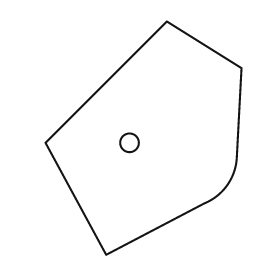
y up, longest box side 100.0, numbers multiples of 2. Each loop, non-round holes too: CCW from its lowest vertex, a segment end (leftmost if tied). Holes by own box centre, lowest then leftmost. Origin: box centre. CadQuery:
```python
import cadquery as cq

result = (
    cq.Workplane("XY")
    .moveTo(-16.0, -50.0)
    .lineTo(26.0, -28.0)
    .threePointArc((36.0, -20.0), (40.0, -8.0))
    .lineTo(42.0, 30.0)
    .lineTo(10.0, 50.0)
    .lineTo(-42.0, -2.0)
    .close()
    .moveTo(-6.0, -2.0)
    .circle(4.0)
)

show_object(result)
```